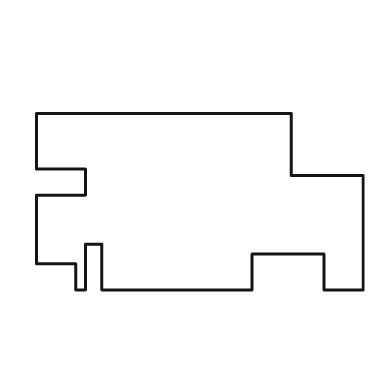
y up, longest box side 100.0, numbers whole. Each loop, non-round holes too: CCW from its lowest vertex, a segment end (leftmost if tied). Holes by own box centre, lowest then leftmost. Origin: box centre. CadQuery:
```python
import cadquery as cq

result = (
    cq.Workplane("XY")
    .moveTo(-38.0, -27.0)
    .lineTo(-35.0, -27.0)
    .lineTo(-35.0, -13.0)
    .lineTo(-30.0, -13.0)
    .lineTo(-30.0, -27.0)
    .lineTo(16.0, -27.0)
    .lineTo(16.0, -16.0)
    .lineTo(38.0, -16.0)
    .lineTo(38.0, -27.0)
    .lineTo(50.0, -27.0)
    .lineTo(50.0, 8.0)
    .lineTo(28.0, 8.0)
    .lineTo(28.0, 27.0)
    .lineTo(-50.0, 27.0)
    .lineTo(-50.0, 10.0)
    .lineTo(-35.0, 10.0)
    .lineTo(-35.0, 2.0)
    .lineTo(-50.0, 2.0)
    .lineTo(-50.0, -19.0)
    .lineTo(-38.0, -19.0)
    .close()
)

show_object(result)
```